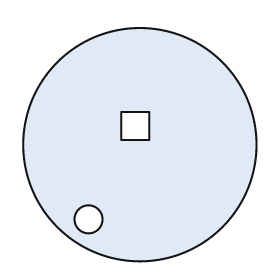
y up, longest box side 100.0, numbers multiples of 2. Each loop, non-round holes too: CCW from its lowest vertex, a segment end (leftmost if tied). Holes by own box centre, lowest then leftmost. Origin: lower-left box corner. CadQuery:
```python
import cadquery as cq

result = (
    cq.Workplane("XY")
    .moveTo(50.0, 50.0)
    .circle(50.0)
    .moveTo(28.0, 18.0)
    .circle(6.0)
    .moveTo(42.0, 52.0)
    .lineTo(54.0, 52.0)
    .lineTo(54.0, 64.0)
    .lineTo(42.0, 64.0)
    .close()
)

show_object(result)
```